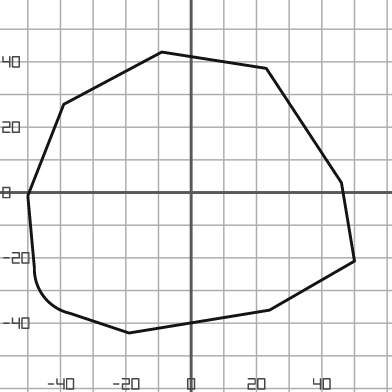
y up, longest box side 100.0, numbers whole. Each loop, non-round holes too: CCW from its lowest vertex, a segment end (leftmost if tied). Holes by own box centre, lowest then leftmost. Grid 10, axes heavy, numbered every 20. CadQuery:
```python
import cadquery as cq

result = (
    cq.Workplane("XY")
    .moveTo(-19.0, -43.0)
    .lineTo(24.0, -36.0)
    .lineTo(50.0, -21.0)
    .lineTo(46.0, 3.0)
    .lineTo(23.0, 38.0)
    .lineTo(-9.0, 43.0)
    .lineTo(-39.0, 27.0)
    .lineTo(-50.0, -1.0)
    .lineTo(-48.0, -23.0)
    .threePointArc((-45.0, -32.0), (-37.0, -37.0))
    .close()
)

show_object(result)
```